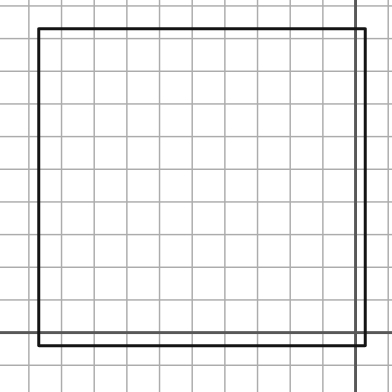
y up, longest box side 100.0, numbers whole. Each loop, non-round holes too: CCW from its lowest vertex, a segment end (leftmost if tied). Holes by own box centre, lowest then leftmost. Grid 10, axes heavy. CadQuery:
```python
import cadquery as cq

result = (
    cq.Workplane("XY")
    .moveTo(-97.0, -4.0)
    .lineTo(3.0, -4.0)
    .lineTo(3.0, 93.0)
    .lineTo(-97.0, 93.0)
    .close()
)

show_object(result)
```